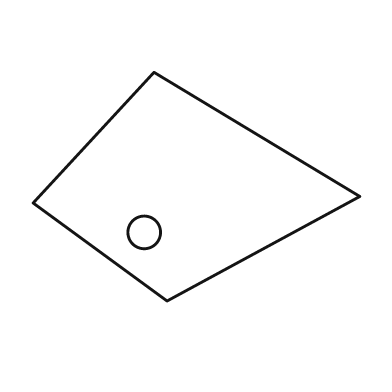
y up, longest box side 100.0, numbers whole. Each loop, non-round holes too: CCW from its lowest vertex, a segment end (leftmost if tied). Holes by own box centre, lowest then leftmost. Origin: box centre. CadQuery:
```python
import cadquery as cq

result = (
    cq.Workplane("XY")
    .moveTo(-9.0, -35.0)
    .lineTo(50.0, -3.0)
    .lineTo(-13.0, 35.0)
    .lineTo(-50.0, -5.0)
    .close()
    .moveTo(-16.0, -14.0)
    .circle(5.0)
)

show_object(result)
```